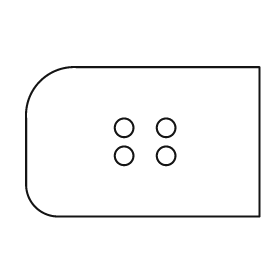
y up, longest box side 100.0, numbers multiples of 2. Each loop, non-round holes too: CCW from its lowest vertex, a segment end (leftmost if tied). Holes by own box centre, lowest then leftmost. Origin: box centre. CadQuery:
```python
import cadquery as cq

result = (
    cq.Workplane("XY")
    .moveTo(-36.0, -32.0)
    .lineTo(50.0, -32.0)
    .lineTo(50.0, 32.0)
    .lineTo(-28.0, 32.0)
    .threePointArc((-44.0, 26.0), (-50.0, 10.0))
    .lineTo(-50.0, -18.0)
    .threePointArc((-46.0, -28.0), (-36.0, -32.0))
    .close()
    .moveTo(-8.0, -6.0)
    .circle(4.0)
    .moveTo(10.0, -6.0)
    .circle(4.0)
    .moveTo(-8.0, 6.0)
    .circle(4.0)
    .moveTo(10.0, 6.0)
    .circle(4.0)
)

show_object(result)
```